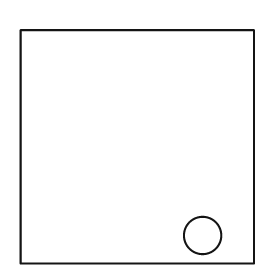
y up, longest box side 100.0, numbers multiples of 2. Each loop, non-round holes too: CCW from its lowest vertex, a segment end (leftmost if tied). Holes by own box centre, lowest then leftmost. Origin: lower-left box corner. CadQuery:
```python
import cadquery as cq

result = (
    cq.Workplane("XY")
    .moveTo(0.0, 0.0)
    .lineTo(100.0, 0.0)
    .lineTo(100.0, 100.0)
    .lineTo(0.0, 100.0)
    .close()
    .moveTo(78.0, 12.0)
    .circle(8.0)
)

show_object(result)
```